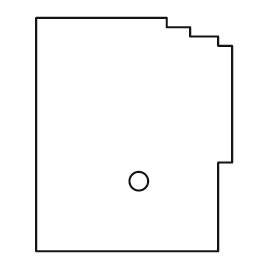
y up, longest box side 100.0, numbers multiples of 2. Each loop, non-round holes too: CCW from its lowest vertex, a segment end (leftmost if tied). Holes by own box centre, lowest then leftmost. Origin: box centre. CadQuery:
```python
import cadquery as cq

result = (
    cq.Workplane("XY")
    .moveTo(-42.0, -50.0)
    .lineTo(36.0, -50.0)
    .lineTo(36.0, -12.0)
    .lineTo(42.0, -12.0)
    .lineTo(42.0, 38.0)
    .lineTo(36.0, 38.0)
    .lineTo(36.0, 42.0)
    .lineTo(24.0, 42.0)
    .lineTo(24.0, 46.0)
    .lineTo(14.0, 46.0)
    .lineTo(14.0, 50.0)
    .lineTo(-42.0, 50.0)
    .close()
    .moveTo(2.0, -20.0)
    .circle(4.0)
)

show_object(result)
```